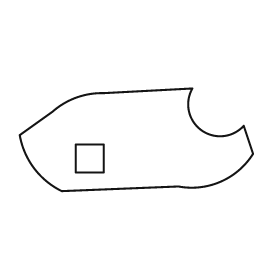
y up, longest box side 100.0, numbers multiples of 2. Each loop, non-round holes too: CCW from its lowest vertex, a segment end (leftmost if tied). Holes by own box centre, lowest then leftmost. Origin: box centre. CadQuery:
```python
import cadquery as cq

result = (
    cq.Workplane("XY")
    .moveTo(-32.0, -22.0)
    .lineTo(18.0, -20.0)
    .threePointArc((36.0, -18.0), (50.0, -6.0))
    .lineTo(46.0, 6.0)
    .threePointArc((28.0, 4.0), (24.0, 22.0))
    .lineTo(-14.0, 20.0)
    .threePointArc((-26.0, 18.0), (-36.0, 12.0))
    .lineTo(-50.0, 2.0)
    .threePointArc((-44.0, -12.0), (-32.0, -22.0))
    .close()
    .moveTo(-26.0, -14.0)
    .lineTo(-14.0, -14.0)
    .lineTo(-14.0, -2.0)
    .lineTo(-26.0, -2.0)
    .close()
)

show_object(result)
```